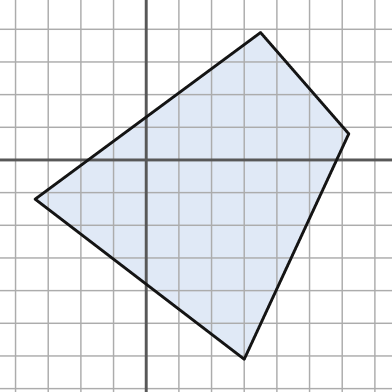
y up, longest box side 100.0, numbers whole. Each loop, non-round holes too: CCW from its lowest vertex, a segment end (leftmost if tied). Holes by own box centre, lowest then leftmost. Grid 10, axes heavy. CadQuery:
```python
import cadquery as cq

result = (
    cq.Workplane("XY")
    .moveTo(30.0, -61.0)
    .lineTo(62.0, 8.0)
    .lineTo(35.0, 39.0)
    .lineTo(-34.0, -12.0)
    .close()
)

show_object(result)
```